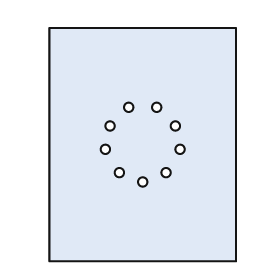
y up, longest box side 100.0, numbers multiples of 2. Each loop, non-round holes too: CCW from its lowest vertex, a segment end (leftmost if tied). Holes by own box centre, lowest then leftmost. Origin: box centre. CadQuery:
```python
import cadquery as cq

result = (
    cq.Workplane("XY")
    .moveTo(-40.0, -50.0)
    .lineTo(40.0, -50.0)
    .lineTo(40.0, 50.0)
    .lineTo(-40.0, 50.0)
    .close()
    .moveTo(0.0, -16.0)
    .circle(2.0)
    .moveTo(-10.0, -12.0)
    .circle(2.0)
    .moveTo(10.0, -12.0)
    .circle(2.0)
    .moveTo(-16.0, -2.0)
    .circle(2.0)
    .moveTo(16.0, -2.0)
    .circle(2.0)
    .moveTo(-14.0, 8.0)
    .circle(2.0)
    .moveTo(14.0, 8.0)
    .circle(2.0)
    .moveTo(-6.0, 16.0)
    .circle(2.0)
    .moveTo(6.0, 16.0)
    .circle(2.0)
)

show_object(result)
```